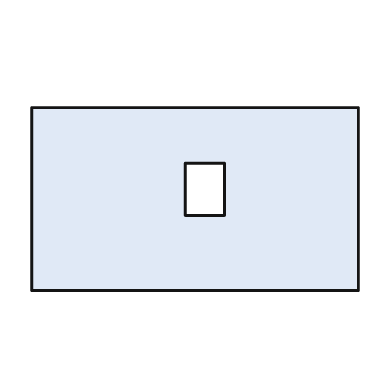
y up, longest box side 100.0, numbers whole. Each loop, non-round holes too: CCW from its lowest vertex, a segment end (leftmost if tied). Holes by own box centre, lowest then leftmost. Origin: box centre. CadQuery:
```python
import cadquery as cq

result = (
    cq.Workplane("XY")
    .moveTo(-50.0, -28.0)
    .lineTo(50.0, -28.0)
    .lineTo(50.0, 28.0)
    .lineTo(-50.0, 28.0)
    .close()
    .moveTo(-3.0, -5.0)
    .lineTo(9.0, -5.0)
    .lineTo(9.0, 11.0)
    .lineTo(-3.0, 11.0)
    .close()
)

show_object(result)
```